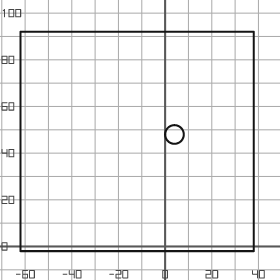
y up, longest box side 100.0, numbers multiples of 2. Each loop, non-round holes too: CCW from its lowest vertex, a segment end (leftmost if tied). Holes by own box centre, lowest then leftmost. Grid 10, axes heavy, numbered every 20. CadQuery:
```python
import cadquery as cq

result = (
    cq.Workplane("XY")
    .moveTo(-62.0, -2.0)
    .lineTo(38.0, -2.0)
    .lineTo(38.0, 92.0)
    .lineTo(-62.0, 92.0)
    .close()
    .moveTo(4.0, 48.0)
    .circle(4.0)
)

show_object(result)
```